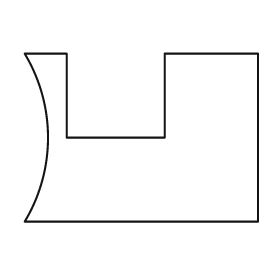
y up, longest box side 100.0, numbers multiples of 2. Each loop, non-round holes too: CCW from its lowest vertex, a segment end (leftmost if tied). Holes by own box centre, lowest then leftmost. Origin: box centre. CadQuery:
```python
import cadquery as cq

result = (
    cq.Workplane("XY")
    .moveTo(-50.0, -36.0)
    .lineTo(50.0, -36.0)
    .lineTo(50.0, 36.0)
    .lineTo(10.0, 36.0)
    .lineTo(10.0, 0.0)
    .lineTo(-32.0, 0.0)
    .lineTo(-32.0, 36.0)
    .lineTo(-50.0, 36.0)
    .threePointArc((-40.0, 0.0), (-50.0, -36.0))
    .close()
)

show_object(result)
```